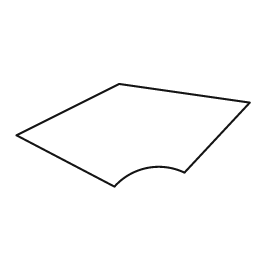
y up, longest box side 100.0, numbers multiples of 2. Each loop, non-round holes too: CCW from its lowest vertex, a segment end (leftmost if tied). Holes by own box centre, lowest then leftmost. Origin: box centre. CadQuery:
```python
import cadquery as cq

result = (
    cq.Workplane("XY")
    .moveTo(-8.0, -22.0)
    .threePointArc((6.0, -14.0), (22.0, -16.0))
    .lineTo(50.0, 14.0)
    .lineTo(-6.0, 22.0)
    .lineTo(-50.0, 0.0)
    .close()
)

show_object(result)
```